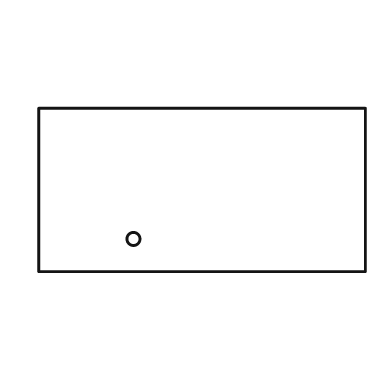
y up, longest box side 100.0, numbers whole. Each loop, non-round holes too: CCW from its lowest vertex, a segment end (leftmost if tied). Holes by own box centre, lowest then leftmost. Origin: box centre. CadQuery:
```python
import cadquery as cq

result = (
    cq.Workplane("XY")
    .moveTo(-50.0, -25.0)
    .lineTo(50.0, -25.0)
    .lineTo(50.0, 25.0)
    .lineTo(-50.0, 25.0)
    .close()
    .moveTo(-21.0, -15.0)
    .circle(2.0)
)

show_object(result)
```